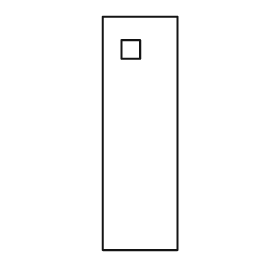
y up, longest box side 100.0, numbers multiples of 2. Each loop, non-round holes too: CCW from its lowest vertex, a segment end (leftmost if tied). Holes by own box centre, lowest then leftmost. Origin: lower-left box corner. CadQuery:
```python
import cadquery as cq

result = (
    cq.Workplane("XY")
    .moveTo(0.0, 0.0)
    .lineTo(32.0, 0.0)
    .lineTo(32.0, 100.0)
    .lineTo(0.0, 100.0)
    .close()
    .moveTo(8.0, 82.0)
    .lineTo(16.0, 82.0)
    .lineTo(16.0, 90.0)
    .lineTo(8.0, 90.0)
    .close()
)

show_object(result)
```